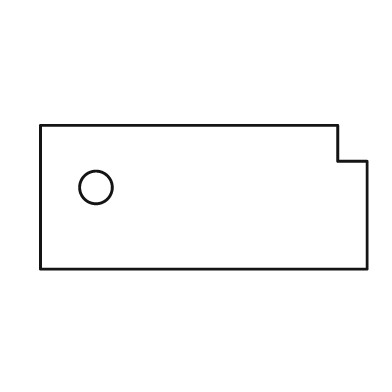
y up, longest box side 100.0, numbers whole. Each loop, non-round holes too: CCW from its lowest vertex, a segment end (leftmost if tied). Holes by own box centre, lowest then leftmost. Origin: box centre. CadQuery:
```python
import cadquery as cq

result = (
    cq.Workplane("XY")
    .moveTo(-50.0, -22.0)
    .lineTo(50.0, -22.0)
    .lineTo(50.0, 11.0)
    .lineTo(41.0, 11.0)
    .lineTo(41.0, 22.0)
    .lineTo(-50.0, 22.0)
    .close()
    .moveTo(-33.0, 3.0)
    .circle(5.0)
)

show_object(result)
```